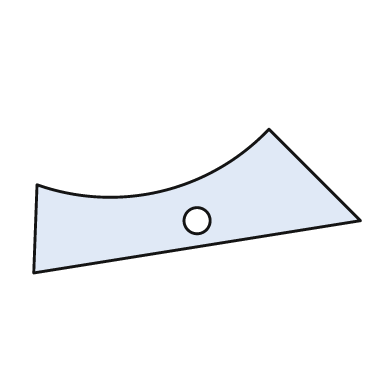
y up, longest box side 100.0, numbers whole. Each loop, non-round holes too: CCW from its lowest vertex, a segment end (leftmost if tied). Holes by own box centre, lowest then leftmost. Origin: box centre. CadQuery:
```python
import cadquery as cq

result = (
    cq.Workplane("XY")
    .moveTo(-50.0, -22.0)
    .lineTo(50.0, -6.0)
    .lineTo(22.0, 22.0)
    .threePointArc((-11.0, 3.0), (-49.0, 5.0))
    .close()
    .moveTo(0.0, -6.0)
    .circle(4.0)
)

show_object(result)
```